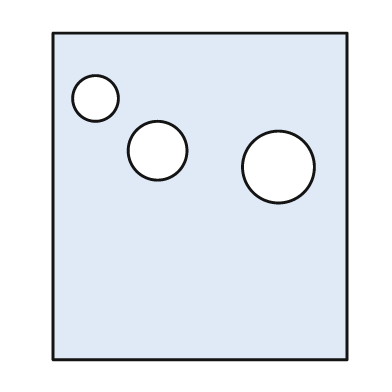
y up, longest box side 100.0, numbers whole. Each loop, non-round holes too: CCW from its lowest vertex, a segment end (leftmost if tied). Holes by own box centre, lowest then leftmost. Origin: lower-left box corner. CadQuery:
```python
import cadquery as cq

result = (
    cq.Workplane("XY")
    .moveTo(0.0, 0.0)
    .lineTo(90.0, 0.0)
    .lineTo(90.0, 100.0)
    .lineTo(0.0, 100.0)
    .close()
    .moveTo(69.0, 59.0)
    .circle(11.0)
    .moveTo(32.0, 64.0)
    .circle(9.0)
    .moveTo(13.0, 80.0)
    .circle(7.0)
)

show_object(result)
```